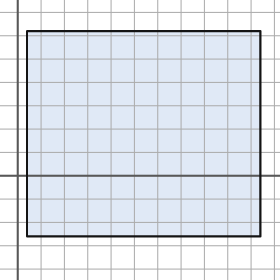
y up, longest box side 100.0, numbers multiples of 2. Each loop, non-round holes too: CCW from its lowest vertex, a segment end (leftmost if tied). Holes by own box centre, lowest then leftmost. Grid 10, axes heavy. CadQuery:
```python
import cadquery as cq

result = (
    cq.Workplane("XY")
    .moveTo(4.0, -26.0)
    .lineTo(104.0, -26.0)
    .lineTo(104.0, 62.0)
    .lineTo(4.0, 62.0)
    .close()
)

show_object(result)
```